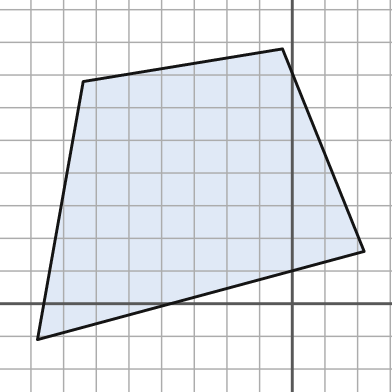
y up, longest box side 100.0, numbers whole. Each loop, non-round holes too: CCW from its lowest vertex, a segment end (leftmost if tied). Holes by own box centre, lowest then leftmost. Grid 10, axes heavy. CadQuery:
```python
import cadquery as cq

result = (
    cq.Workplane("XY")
    .moveTo(-78.0, -11.0)
    .lineTo(22.0, 16.0)
    .lineTo(-3.0, 78.0)
    .lineTo(-64.0, 68.0)
    .close()
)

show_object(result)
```